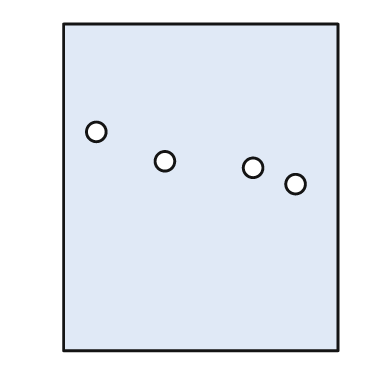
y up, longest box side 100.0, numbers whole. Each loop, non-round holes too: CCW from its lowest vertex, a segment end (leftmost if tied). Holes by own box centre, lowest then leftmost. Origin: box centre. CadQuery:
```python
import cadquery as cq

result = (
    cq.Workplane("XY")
    .moveTo(-42.0, -50.0)
    .lineTo(42.0, -50.0)
    .lineTo(42.0, 50.0)
    .lineTo(-42.0, 50.0)
    .close()
    .moveTo(29.0, 1.0)
    .circle(3.0)
    .moveTo(16.0, 6.0)
    .circle(3.0)
    .moveTo(-11.0, 8.0)
    .circle(3.0)
    .moveTo(-32.0, 17.0)
    .circle(3.0)
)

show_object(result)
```